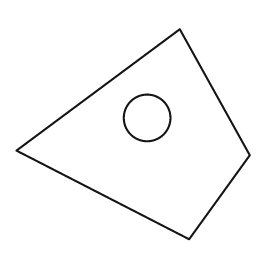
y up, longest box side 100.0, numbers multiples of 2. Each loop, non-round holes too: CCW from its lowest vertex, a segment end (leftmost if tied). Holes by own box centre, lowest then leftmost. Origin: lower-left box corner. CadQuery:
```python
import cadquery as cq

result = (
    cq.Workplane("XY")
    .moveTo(74.0, 0.0)
    .lineTo(100.0, 36.0)
    .lineTo(70.0, 90.0)
    .lineTo(0.0, 38.0)
    .close()
    .moveTo(56.0, 52.0)
    .circle(10.0)
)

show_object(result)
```